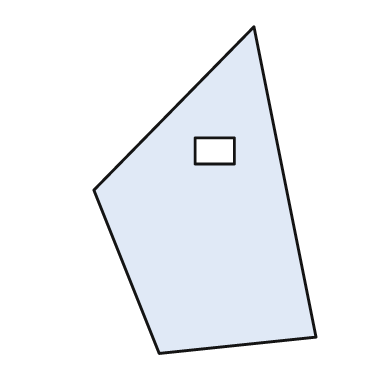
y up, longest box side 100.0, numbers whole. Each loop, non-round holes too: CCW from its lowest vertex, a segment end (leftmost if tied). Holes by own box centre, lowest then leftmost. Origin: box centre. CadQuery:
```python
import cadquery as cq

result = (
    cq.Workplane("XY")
    .moveTo(-14.0, -50.0)
    .lineTo(34.0, -45.0)
    .lineTo(15.0, 50.0)
    .lineTo(-34.0, 0.0)
    .close()
    .moveTo(-3.0, 8.0)
    .lineTo(9.0, 8.0)
    .lineTo(9.0, 16.0)
    .lineTo(-3.0, 16.0)
    .close()
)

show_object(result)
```